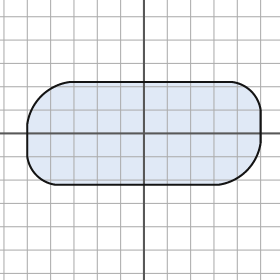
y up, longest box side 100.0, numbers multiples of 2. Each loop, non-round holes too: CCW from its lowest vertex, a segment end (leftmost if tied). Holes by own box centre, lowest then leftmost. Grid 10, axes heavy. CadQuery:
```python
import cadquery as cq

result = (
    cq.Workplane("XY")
    .moveTo(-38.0, -22.0)
    .lineTo(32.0, -22.0)
    .threePointArc((44.0, -16.0), (50.0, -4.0))
    .lineTo(50.0, 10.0)
    .threePointArc((46.0, 18.0), (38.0, 22.0))
    .lineTo(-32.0, 22.0)
    .threePointArc((-44.0, 16.0), (-50.0, 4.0))
    .lineTo(-50.0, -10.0)
    .threePointArc((-46.0, -18.0), (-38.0, -22.0))
    .close()
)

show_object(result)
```